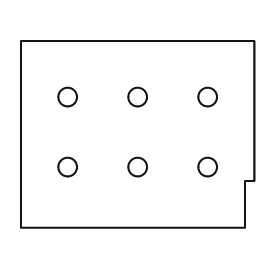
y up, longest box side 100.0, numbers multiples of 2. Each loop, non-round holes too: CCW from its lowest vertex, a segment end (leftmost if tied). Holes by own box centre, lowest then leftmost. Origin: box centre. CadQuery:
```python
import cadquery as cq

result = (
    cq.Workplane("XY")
    .moveTo(-50.0, -40.0)
    .lineTo(46.0, -40.0)
    .lineTo(46.0, -20.0)
    .lineTo(50.0, -20.0)
    .lineTo(50.0, 40.0)
    .lineTo(-50.0, 40.0)
    .close()
    .moveTo(-30.0, -14.0)
    .circle(4.0)
    .moveTo(0.0, -14.0)
    .circle(4.0)
    .moveTo(30.0, -14.0)
    .circle(4.0)
    .moveTo(-30.0, 16.0)
    .circle(4.0)
    .moveTo(0.0, 16.0)
    .circle(4.0)
    .moveTo(30.0, 16.0)
    .circle(4.0)
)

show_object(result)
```